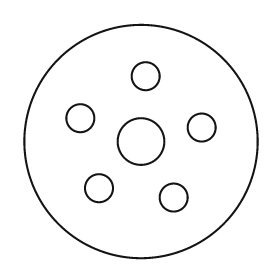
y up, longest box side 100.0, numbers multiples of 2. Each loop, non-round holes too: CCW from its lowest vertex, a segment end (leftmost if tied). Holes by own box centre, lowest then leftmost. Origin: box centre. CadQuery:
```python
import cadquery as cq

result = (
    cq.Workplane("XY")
    .moveTo(0.0, 0.0)
    .circle(50.0)
    .moveTo(14.0, -24.0)
    .circle(6.0)
    .moveTo(-18.0, -20.0)
    .circle(6.0)
    .moveTo(0.0, 0.0)
    .circle(10.0)
    .moveTo(26.0, 6.0)
    .circle(6.0)
    .moveTo(-26.0, 10.0)
    .circle(6.0)
    .moveTo(2.0, 28.0)
    .circle(6.0)
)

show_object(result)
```